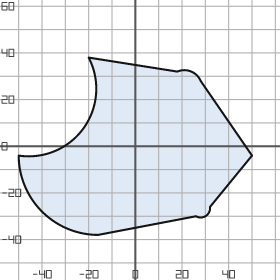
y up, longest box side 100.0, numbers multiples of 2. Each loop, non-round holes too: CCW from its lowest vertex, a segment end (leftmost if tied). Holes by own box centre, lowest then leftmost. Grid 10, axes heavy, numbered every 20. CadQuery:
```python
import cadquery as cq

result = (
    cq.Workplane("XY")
    .moveTo(-16.0, -38.0)
    .lineTo(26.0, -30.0)
    .threePointArc((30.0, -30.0), (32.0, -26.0))
    .lineTo(50.0, -4.0)
    .lineTo(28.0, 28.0)
    .threePointArc((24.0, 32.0), (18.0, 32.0))
    .lineTo(-20.0, 38.0)
    .threePointArc((-22.0, 8.0), (-50.0, -4.0))
    .threePointArc((-40.0, -28.0), (-16.0, -38.0))
    .close()
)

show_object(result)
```